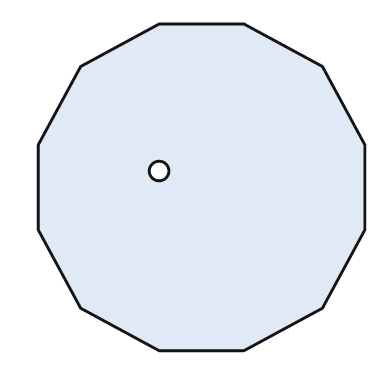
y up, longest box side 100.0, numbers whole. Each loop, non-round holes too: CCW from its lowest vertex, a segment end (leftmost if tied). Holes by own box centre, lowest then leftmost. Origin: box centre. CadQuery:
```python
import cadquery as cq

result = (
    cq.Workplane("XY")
    .moveTo(-13.0, -50.0)
    .lineTo(13.0, -50.0)
    .lineTo(37.0, -37.0)
    .lineTo(50.0, -13.0)
    .lineTo(50.0, 13.0)
    .lineTo(37.0, 37.0)
    .lineTo(13.0, 50.0)
    .lineTo(-13.0, 50.0)
    .lineTo(-37.0, 37.0)
    .lineTo(-50.0, 13.0)
    .lineTo(-50.0, -13.0)
    .lineTo(-37.0, -37.0)
    .close()
    .moveTo(-13.0, 5.0)
    .circle(3.0)
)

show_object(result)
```